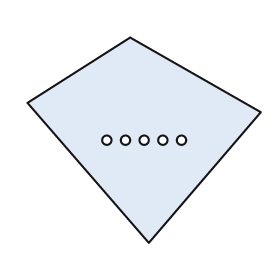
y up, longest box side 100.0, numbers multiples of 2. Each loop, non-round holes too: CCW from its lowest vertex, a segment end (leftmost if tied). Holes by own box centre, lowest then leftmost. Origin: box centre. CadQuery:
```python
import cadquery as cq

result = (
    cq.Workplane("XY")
    .moveTo(2.0, -44.0)
    .lineTo(50.0, 12.0)
    .lineTo(-6.0, 44.0)
    .lineTo(-50.0, 16.0)
    .close()
    .moveTo(-16.0, 0.0)
    .circle(2.0)
    .moveTo(-8.0, 0.0)
    .circle(2.0)
    .moveTo(0.0, 0.0)
    .circle(2.0)
    .moveTo(8.0, 0.0)
    .circle(2.0)
    .moveTo(16.0, 0.0)
    .circle(2.0)
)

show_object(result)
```